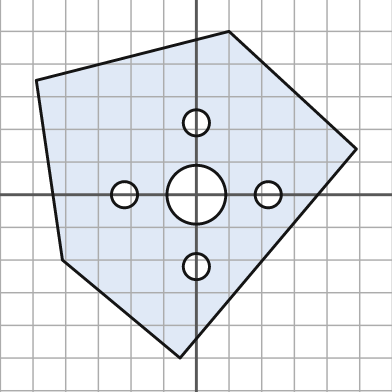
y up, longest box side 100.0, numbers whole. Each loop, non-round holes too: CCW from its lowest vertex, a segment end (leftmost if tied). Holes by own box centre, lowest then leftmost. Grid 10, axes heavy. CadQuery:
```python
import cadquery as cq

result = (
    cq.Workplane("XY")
    .moveTo(-5.0, -50.0)
    .lineTo(49.0, 14.0)
    .lineTo(10.0, 50.0)
    .lineTo(-49.0, 35.0)
    .lineTo(-41.0, -20.0)
    .close()
    .moveTo(0.0, -22.0)
    .circle(4.0)
    .moveTo(-22.0, 0.0)
    .circle(4.0)
    .moveTo(0.0, 0.0)
    .circle(9.0)
    .moveTo(22.0, 0.0)
    .circle(4.0)
    .moveTo(0.0, 22.0)
    .circle(4.0)
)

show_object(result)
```